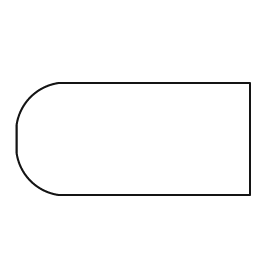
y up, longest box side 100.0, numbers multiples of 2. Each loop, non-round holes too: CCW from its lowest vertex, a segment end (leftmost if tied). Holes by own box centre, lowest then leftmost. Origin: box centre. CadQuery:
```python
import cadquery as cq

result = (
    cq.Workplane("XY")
    .moveTo(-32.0, -24.0)
    .lineTo(50.0, -24.0)
    .lineTo(50.0, 24.0)
    .lineTo(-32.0, 24.0)
    .threePointArc((-44.0, 18.0), (-50.0, 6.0))
    .lineTo(-50.0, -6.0)
    .threePointArc((-44.0, -18.0), (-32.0, -24.0))
    .close()
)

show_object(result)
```